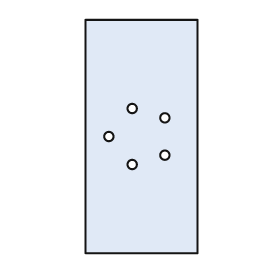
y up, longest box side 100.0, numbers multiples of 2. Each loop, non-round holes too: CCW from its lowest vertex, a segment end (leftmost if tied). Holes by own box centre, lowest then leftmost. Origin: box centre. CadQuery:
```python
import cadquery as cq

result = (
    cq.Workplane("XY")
    .moveTo(-24.0, -50.0)
    .lineTo(24.0, -50.0)
    .lineTo(24.0, 50.0)
    .lineTo(-24.0, 50.0)
    .close()
    .moveTo(-4.0, -12.0)
    .circle(2.0)
    .moveTo(10.0, -8.0)
    .circle(2.0)
    .moveTo(-14.0, 0.0)
    .circle(2.0)
    .moveTo(10.0, 8.0)
    .circle(2.0)
    .moveTo(-4.0, 12.0)
    .circle(2.0)
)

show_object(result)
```